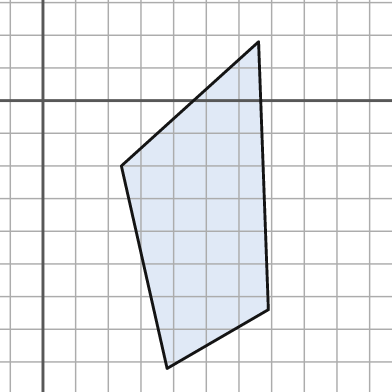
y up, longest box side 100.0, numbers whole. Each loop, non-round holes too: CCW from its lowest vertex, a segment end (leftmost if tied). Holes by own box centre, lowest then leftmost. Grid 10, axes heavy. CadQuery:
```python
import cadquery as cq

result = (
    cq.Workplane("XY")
    .moveTo(38.0, -82.0)
    .lineTo(69.0, -64.0)
    .lineTo(66.0, 18.0)
    .lineTo(24.0, -20.0)
    .close()
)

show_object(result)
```